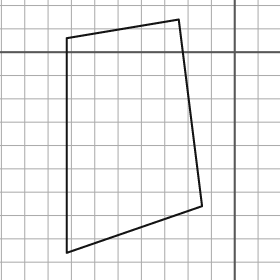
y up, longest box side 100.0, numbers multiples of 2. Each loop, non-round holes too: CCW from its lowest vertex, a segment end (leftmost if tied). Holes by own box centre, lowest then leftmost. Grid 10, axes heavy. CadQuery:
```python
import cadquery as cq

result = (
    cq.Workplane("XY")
    .moveTo(-72.0, -86.0)
    .lineTo(-14.0, -66.0)
    .lineTo(-24.0, 14.0)
    .lineTo(-72.0, 6.0)
    .close()
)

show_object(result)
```